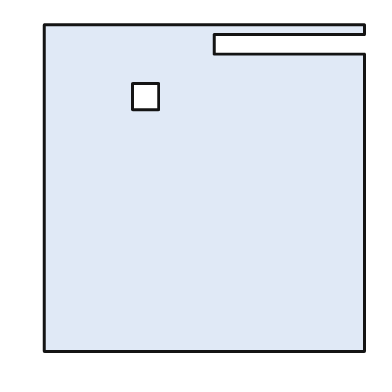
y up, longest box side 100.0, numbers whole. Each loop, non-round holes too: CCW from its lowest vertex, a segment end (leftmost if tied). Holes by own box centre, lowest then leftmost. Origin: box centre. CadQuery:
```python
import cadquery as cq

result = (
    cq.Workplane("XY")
    .moveTo(-49.0, -50.0)
    .lineTo(49.0, -50.0)
    .lineTo(49.0, 41.0)
    .lineTo(3.0, 41.0)
    .lineTo(3.0, 47.0)
    .lineTo(49.0, 47.0)
    .lineTo(49.0, 50.0)
    .lineTo(-49.0, 50.0)
    .close()
    .moveTo(-22.0, 24.0)
    .lineTo(-14.0, 24.0)
    .lineTo(-14.0, 32.0)
    .lineTo(-22.0, 32.0)
    .close()
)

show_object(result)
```